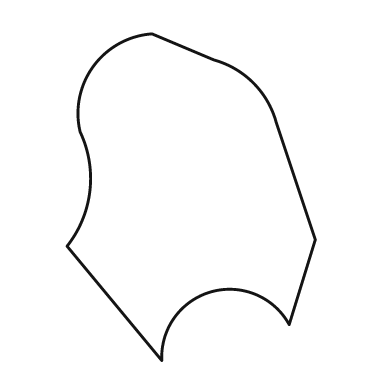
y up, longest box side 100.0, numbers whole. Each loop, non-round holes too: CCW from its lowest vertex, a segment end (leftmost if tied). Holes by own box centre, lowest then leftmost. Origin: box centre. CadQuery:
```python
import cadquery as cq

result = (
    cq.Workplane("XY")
    .moveTo(-9.0, -50.0)
    .threePointArc((6.0, -29.0), (30.0, -39.0))
    .lineTo(38.0, -13.0)
    .lineTo(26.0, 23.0)
    .threePointArc((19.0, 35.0), (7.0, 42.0))
    .lineTo(-12.0, 50.0)
    .threePointArc((-30.0, 40.0), (-34.0, 20.0))
    .threePointArc((-31.0, 2.0), (-38.0, -15.0))
    .close()
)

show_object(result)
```